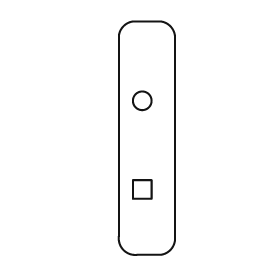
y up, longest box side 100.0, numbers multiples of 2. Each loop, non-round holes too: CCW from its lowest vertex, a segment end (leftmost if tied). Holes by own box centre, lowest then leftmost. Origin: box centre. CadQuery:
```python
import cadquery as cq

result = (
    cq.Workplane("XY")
    .moveTo(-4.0, -50.0)
    .lineTo(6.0, -50.0)
    .threePointArc((10.0, -48.0), (12.0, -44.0))
    .lineTo(12.0, 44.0)
    .threePointArc((10.0, 48.0), (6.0, 50.0))
    .lineTo(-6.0, 50.0)
    .threePointArc((-10.0, 48.0), (-12.0, 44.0))
    .lineTo(-12.0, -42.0)
    .threePointArc((-10.0, -48.0), (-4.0, -50.0))
    .close()
    .moveTo(-6.0, -26.0)
    .lineTo(2.0, -26.0)
    .lineTo(2.0, -18.0)
    .lineTo(-6.0, -18.0)
    .close()
    .moveTo(-2.0, 16.0)
    .circle(4.0)
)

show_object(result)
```